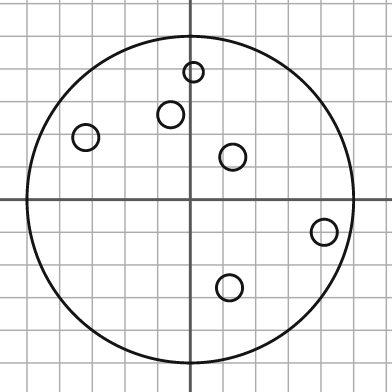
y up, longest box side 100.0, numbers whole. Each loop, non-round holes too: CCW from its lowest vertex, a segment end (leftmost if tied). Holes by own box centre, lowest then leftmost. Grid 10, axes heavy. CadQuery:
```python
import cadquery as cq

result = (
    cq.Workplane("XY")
    .moveTo(0.0, 0.0)
    .circle(50.0)
    .moveTo(12.0, -27.0)
    .circle(4.0)
    .moveTo(41.0, -10.0)
    .circle(4.0)
    .moveTo(13.0, 13.0)
    .circle(4.0)
    .moveTo(-32.0, 19.0)
    .circle(4.0)
    .moveTo(-6.0, 26.0)
    .circle(4.0)
    .moveTo(1.0, 39.0)
    .circle(3.0)
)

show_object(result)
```